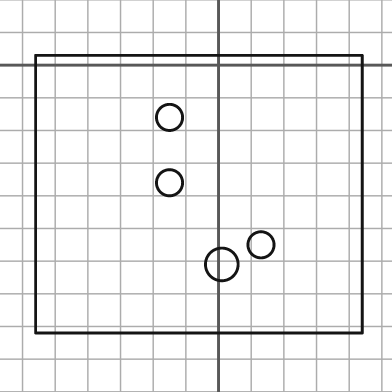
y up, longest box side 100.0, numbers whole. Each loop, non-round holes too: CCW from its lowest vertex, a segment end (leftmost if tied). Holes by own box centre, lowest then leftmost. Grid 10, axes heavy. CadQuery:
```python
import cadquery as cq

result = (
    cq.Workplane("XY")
    .moveTo(-56.0, -82.0)
    .lineTo(44.0, -82.0)
    .lineTo(44.0, 3.0)
    .lineTo(-56.0, 3.0)
    .close()
    .moveTo(1.0, -61.0)
    .circle(5.0)
    .moveTo(13.0, -55.0)
    .circle(4.0)
    .moveTo(-15.0, -36.0)
    .circle(4.0)
    .moveTo(-15.0, -16.0)
    .circle(4.0)
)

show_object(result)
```